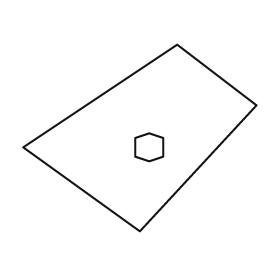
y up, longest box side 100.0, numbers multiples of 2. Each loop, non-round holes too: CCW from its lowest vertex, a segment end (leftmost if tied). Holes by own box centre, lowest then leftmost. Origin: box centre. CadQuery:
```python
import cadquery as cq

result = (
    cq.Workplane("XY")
    .moveTo(0.0, -40.0)
    .lineTo(50.0, 14.0)
    .lineTo(16.0, 40.0)
    .lineTo(-50.0, -4.0)
    .close()
    .moveTo(4.0, -10.0)
    .lineTo(10.0, -8.0)
    .lineTo(10.0, 0.0)
    .lineTo(4.0, 2.0)
    .lineTo(-2.0, 0.0)
    .lineTo(-2.0, -8.0)
    .close()
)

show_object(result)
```